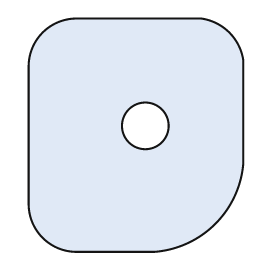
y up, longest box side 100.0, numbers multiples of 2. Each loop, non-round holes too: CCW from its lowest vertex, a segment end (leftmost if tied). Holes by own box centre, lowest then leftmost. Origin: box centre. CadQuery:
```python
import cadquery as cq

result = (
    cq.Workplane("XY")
    .moveTo(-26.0, -50.0)
    .lineTo(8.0, -50.0)
    .threePointArc((34.0, -38.0), (46.0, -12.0))
    .lineTo(46.0, 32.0)
    .threePointArc((40.0, 44.0), (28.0, 50.0))
    .lineTo(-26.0, 50.0)
    .threePointArc((-40.0, 44.0), (-46.0, 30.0))
    .lineTo(-46.0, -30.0)
    .threePointArc((-40.0, -44.0), (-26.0, -50.0))
    .close()
    .moveTo(4.0, 4.0)
    .circle(10.0)
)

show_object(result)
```